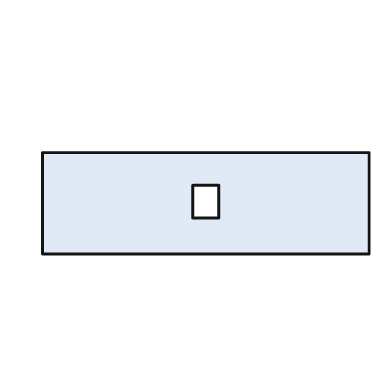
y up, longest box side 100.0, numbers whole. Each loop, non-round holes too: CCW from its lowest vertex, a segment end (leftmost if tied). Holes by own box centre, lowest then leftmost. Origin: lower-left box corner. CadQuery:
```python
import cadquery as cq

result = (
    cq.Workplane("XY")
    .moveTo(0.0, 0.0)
    .lineTo(100.0, 0.0)
    .lineTo(100.0, 31.0)
    .lineTo(0.0, 31.0)
    .close()
    .moveTo(46.0, 11.0)
    .lineTo(54.0, 11.0)
    .lineTo(54.0, 21.0)
    .lineTo(46.0, 21.0)
    .close()
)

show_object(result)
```